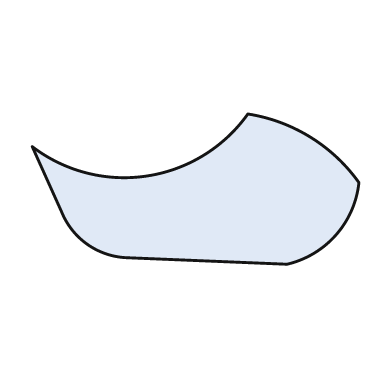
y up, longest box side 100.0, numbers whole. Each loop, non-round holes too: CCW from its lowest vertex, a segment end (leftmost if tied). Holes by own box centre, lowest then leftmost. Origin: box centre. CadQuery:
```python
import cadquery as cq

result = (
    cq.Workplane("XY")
    .moveTo(28.0, -23.0)
    .threePointArc((43.0, -14.0), (50.0, 2.0))
    .threePointArc((35.0, 16.0), (16.0, 23.0))
    .threePointArc((-15.0, 4.0), (-50.0, 13.0))
    .lineTo(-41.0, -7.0)
    .threePointArc((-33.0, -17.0), (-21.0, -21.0))
    .close()
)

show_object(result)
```